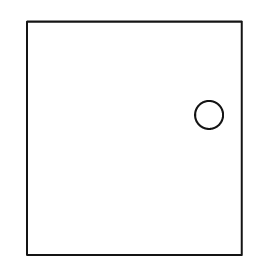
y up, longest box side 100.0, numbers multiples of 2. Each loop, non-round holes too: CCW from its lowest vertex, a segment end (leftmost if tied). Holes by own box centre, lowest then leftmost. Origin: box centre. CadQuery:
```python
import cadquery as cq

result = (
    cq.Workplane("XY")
    .moveTo(-46.0, -50.0)
    .lineTo(46.0, -50.0)
    .lineTo(46.0, 50.0)
    .lineTo(-46.0, 50.0)
    .close()
    .moveTo(32.0, 10.0)
    .circle(6.0)
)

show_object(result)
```